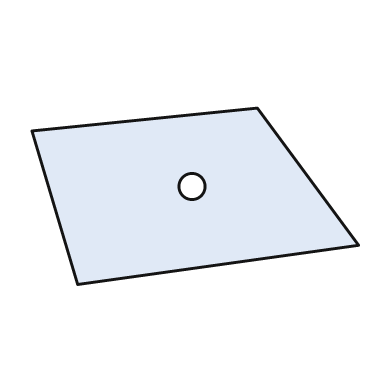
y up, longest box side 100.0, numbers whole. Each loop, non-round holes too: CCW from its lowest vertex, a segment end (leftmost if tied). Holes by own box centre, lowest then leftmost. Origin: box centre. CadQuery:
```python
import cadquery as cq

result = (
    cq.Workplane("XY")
    .moveTo(-36.0, -27.0)
    .lineTo(50.0, -15.0)
    .lineTo(19.0, 27.0)
    .lineTo(-50.0, 20.0)
    .close()
    .moveTo(-1.0, 3.0)
    .circle(4.0)
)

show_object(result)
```